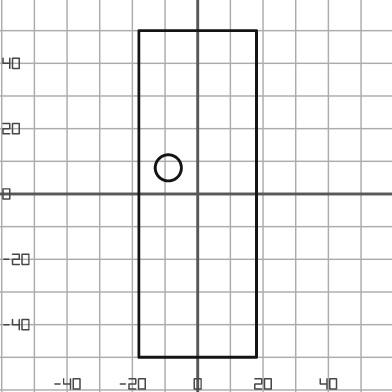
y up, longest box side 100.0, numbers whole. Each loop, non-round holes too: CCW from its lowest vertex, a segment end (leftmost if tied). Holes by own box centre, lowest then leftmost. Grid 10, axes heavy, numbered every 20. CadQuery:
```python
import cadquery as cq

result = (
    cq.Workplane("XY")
    .moveTo(-18.0, -50.0)
    .lineTo(18.0, -50.0)
    .lineTo(18.0, 50.0)
    .lineTo(-18.0, 50.0)
    .close()
    .moveTo(-9.0, 8.0)
    .circle(4.0)
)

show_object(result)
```